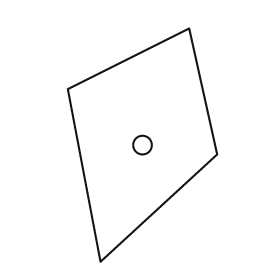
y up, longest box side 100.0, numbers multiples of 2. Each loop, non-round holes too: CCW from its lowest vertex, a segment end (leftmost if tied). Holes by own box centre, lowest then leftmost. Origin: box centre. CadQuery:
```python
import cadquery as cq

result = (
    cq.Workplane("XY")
    .moveTo(-18.0, -50.0)
    .lineTo(32.0, -4.0)
    .lineTo(20.0, 50.0)
    .lineTo(-32.0, 24.0)
    .close()
    .moveTo(0.0, 0.0)
    .circle(4.0)
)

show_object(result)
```